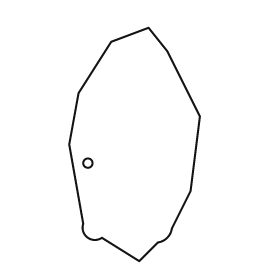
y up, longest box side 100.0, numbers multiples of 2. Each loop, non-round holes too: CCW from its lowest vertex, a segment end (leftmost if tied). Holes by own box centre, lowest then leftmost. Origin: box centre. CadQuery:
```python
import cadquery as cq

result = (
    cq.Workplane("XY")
    .moveTo(2.0, -50.0)
    .lineTo(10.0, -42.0)
    .threePointArc((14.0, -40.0), (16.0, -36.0))
    .lineTo(24.0, -20.0)
    .lineTo(28.0, 12.0)
    .lineTo(14.0, 40.0)
    .lineTo(6.0, 50.0)
    .lineTo(-10.0, 44.0)
    .lineTo(-24.0, 22.0)
    .lineTo(-28.0, 0.0)
    .lineTo(-22.0, -34.0)
    .threePointArc((-20.0, -40.0), (-14.0, -40.0))
    .close()
    .moveTo(-20.0, -8.0)
    .circle(2.0)
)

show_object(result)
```